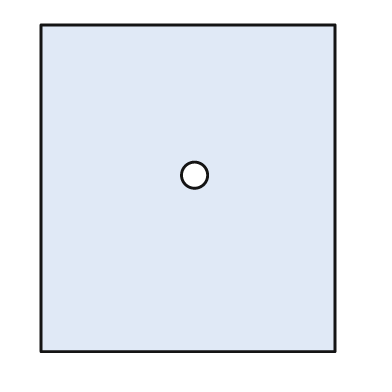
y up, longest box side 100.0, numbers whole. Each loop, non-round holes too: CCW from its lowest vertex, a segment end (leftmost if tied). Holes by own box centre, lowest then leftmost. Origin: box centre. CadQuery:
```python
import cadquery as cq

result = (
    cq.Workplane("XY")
    .moveTo(-45.0, -50.0)
    .lineTo(45.0, -50.0)
    .lineTo(45.0, 50.0)
    .lineTo(-45.0, 50.0)
    .close()
    .moveTo(2.0, 4.0)
    .circle(4.0)
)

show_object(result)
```